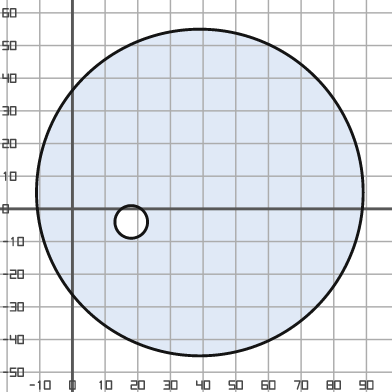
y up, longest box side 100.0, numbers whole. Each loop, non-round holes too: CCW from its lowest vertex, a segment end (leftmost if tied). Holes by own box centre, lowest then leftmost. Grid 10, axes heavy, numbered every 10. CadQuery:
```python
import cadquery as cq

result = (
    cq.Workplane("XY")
    .moveTo(39.0, 5.0)
    .circle(50.0)
    .moveTo(18.0, -4.0)
    .circle(5.0)
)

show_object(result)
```